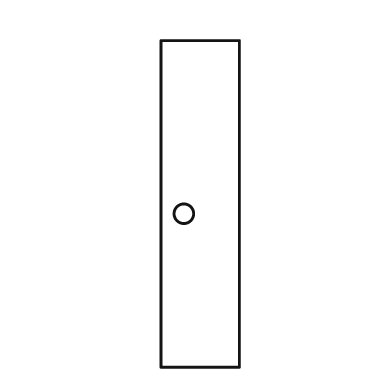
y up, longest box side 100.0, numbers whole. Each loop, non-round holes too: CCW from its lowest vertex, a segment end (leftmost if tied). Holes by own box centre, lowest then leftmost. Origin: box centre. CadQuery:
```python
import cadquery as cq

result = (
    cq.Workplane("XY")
    .moveTo(-12.0, -50.0)
    .lineTo(12.0, -50.0)
    .lineTo(12.0, 50.0)
    .lineTo(-12.0, 50.0)
    .close()
    .moveTo(-5.0, -3.0)
    .circle(3.0)
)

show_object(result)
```